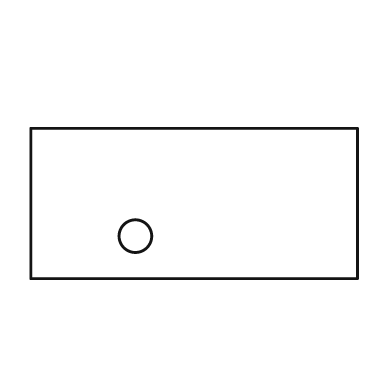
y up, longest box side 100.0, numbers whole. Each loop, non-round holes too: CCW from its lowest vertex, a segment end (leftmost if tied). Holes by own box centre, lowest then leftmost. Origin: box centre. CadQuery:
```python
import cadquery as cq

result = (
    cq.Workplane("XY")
    .moveTo(-50.0, -23.0)
    .lineTo(50.0, -23.0)
    .lineTo(50.0, 23.0)
    .lineTo(-50.0, 23.0)
    .close()
    .moveTo(-18.0, -10.0)
    .circle(5.0)
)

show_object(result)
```